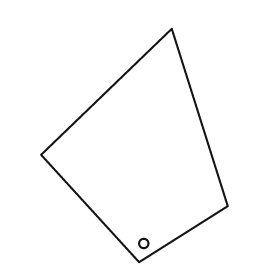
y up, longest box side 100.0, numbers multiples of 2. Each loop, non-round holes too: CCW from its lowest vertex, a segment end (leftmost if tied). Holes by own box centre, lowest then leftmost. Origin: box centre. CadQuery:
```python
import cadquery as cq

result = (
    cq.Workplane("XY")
    .moveTo(2.0, -50.0)
    .lineTo(40.0, -26.0)
    .lineTo(16.0, 50.0)
    .lineTo(-40.0, -4.0)
    .close()
    .moveTo(4.0, -42.0)
    .circle(2.0)
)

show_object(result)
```